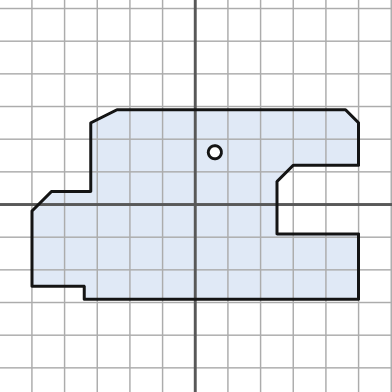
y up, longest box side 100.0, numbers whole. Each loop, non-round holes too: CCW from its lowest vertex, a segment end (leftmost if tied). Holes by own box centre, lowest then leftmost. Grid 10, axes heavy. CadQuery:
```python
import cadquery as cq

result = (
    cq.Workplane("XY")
    .moveTo(-34.0, -29.0)
    .lineTo(50.0, -29.0)
    .lineTo(50.0, -9.0)
    .lineTo(25.0, -9.0)
    .lineTo(25.0, 7.0)
    .lineTo(30.0, 12.0)
    .lineTo(50.0, 12.0)
    .lineTo(50.0, 25.0)
    .lineTo(46.0, 29.0)
    .lineTo(-24.0, 29.0)
    .lineTo(-32.0, 25.0)
    .lineTo(-32.0, 4.0)
    .lineTo(-44.0, 4.0)
    .lineTo(-50.0, -2.0)
    .lineTo(-50.0, -25.0)
    .lineTo(-34.0, -25.0)
    .close()
    .moveTo(6.0, 16.0)
    .circle(2.0)
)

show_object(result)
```